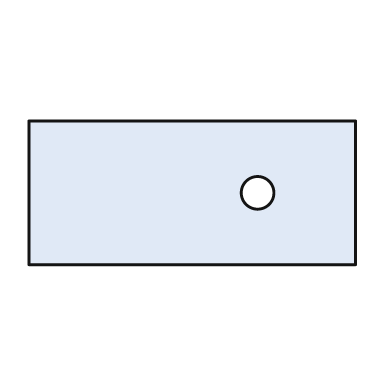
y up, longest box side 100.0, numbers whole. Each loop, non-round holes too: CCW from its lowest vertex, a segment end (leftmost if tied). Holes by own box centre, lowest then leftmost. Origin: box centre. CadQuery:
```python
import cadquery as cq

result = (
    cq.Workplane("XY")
    .moveTo(-50.0, -22.0)
    .lineTo(50.0, -22.0)
    .lineTo(50.0, 22.0)
    .lineTo(-50.0, 22.0)
    .close()
    .moveTo(20.0, 0.0)
    .circle(5.0)
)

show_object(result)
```